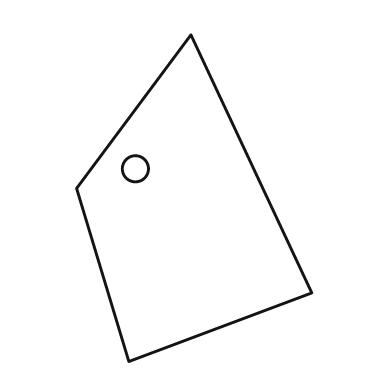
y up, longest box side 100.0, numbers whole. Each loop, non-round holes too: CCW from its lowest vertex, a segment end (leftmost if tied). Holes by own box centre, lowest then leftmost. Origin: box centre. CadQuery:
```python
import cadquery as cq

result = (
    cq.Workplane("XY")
    .moveTo(-20.0, -50.0)
    .lineTo(36.0, -29.0)
    .lineTo(-1.0, 50.0)
    .lineTo(-36.0, 3.0)
    .close()
    .moveTo(-18.0, 9.0)
    .circle(4.0)
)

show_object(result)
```